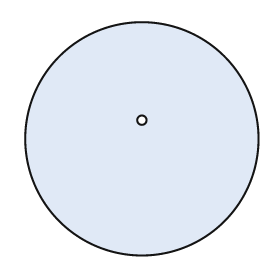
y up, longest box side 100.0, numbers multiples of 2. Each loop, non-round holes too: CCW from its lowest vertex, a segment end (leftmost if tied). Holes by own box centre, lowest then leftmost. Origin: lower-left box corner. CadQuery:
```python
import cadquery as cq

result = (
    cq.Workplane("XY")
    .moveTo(50.0, 50.0)
    .circle(50.0)
    .moveTo(50.0, 58.0)
    .circle(2.0)
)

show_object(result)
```